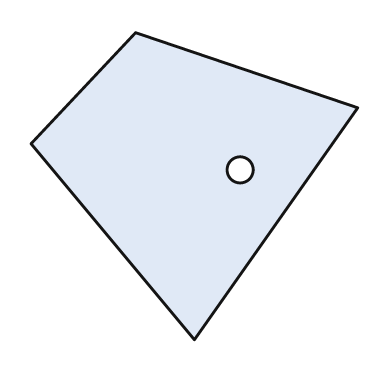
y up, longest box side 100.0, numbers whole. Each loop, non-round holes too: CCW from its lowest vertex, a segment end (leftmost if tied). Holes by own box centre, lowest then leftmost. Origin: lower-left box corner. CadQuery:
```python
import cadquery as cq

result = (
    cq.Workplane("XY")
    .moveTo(50.0, 0.0)
    .lineTo(100.0, 71.0)
    .lineTo(32.0, 94.0)
    .lineTo(0.0, 60.0)
    .close()
    .moveTo(64.0, 52.0)
    .circle(4.0)
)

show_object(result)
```